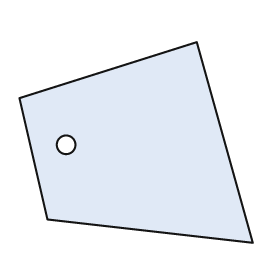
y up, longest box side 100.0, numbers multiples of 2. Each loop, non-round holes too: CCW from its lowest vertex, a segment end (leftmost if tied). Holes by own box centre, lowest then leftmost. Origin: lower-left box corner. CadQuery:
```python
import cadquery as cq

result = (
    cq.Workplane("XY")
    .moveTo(100.0, 0.0)
    .lineTo(76.0, 86.0)
    .lineTo(0.0, 62.0)
    .lineTo(12.0, 10.0)
    .close()
    .moveTo(20.0, 42.0)
    .circle(4.0)
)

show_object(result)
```